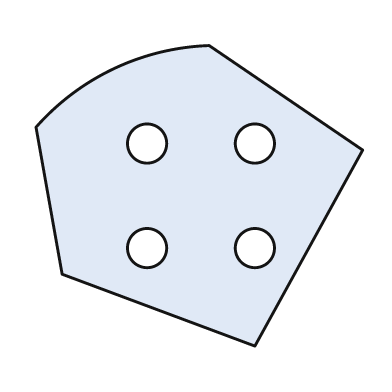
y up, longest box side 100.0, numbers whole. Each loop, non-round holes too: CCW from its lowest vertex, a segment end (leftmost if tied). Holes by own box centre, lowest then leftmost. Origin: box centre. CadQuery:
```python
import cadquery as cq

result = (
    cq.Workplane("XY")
    .moveTo(17.0, -46.0)
    .lineTo(50.0, 14.0)
    .lineTo(3.0, 46.0)
    .threePointArc((-26.0, 39.0), (-50.0, 21.0))
    .lineTo(-42.0, -24.0)
    .close()
    .moveTo(-16.0, -16.0)
    .circle(6.0)
    .moveTo(17.0, -16.0)
    .circle(6.0)
    .moveTo(-16.0, 16.0)
    .circle(6.0)
    .moveTo(17.0, 16.0)
    .circle(6.0)
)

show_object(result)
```